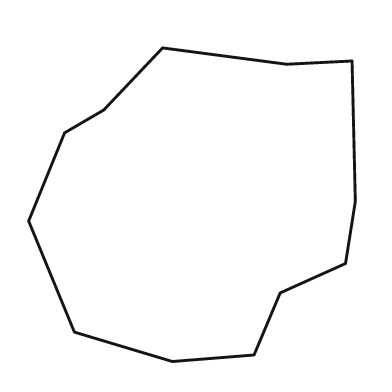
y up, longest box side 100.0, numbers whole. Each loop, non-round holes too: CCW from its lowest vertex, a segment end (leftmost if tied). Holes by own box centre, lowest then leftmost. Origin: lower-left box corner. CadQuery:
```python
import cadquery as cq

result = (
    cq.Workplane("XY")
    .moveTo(44.0, 0.0)
    .lineTo(69.0, 2.0)
    .lineTo(77.0, 21.0)
    .lineTo(97.0, 30.0)
    .lineTo(100.0, 49.0)
    .lineTo(99.0, 92.0)
    .lineTo(79.0, 91.0)
    .lineTo(41.0, 96.0)
    .lineTo(23.0, 77.0)
    .lineTo(11.0, 70.0)
    .lineTo(0.0, 43.0)
    .lineTo(14.0, 9.0)
    .close()
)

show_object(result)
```